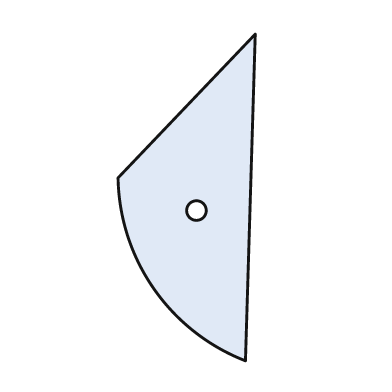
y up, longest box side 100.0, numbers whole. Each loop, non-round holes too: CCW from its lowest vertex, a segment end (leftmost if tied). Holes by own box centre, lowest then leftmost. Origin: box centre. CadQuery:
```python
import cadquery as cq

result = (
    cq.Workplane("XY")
    .moveTo(18.0, -50.0)
    .lineTo(21.0, 50.0)
    .lineTo(-21.0, 6.0)
    .threePointArc((-10.0, -28.0), (18.0, -50.0))
    .close()
    .moveTo(3.0, -4.0)
    .circle(3.0)
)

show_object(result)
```